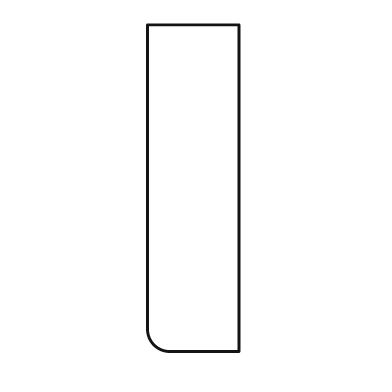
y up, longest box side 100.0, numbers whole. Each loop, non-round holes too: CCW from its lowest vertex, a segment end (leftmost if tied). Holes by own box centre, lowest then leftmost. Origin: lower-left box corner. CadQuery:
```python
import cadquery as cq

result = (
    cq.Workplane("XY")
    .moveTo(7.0, 0.0)
    .lineTo(28.0, 0.0)
    .lineTo(28.0, 100.0)
    .lineTo(0.0, 100.0)
    .lineTo(0.0, 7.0)
    .threePointArc((2.0, 2.0), (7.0, 0.0))
    .close()
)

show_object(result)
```